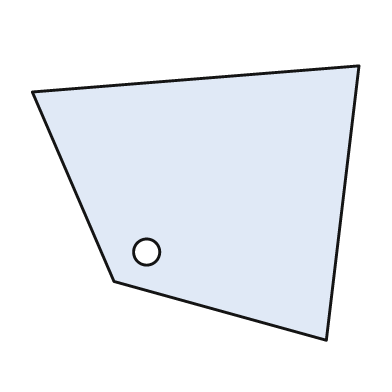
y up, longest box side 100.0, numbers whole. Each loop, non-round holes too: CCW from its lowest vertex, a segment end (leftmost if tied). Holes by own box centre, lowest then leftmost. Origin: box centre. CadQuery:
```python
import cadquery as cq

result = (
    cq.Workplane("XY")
    .moveTo(40.0, -42.0)
    .lineTo(50.0, 42.0)
    .lineTo(-50.0, 34.0)
    .lineTo(-25.0, -24.0)
    .close()
    .moveTo(-15.0, -15.0)
    .circle(4.0)
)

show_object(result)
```